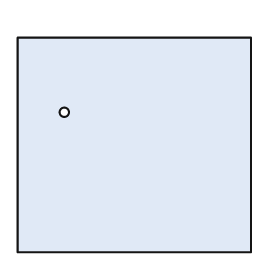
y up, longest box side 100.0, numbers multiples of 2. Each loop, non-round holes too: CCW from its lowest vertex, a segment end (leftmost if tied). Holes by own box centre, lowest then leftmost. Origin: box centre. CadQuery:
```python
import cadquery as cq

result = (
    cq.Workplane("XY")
    .moveTo(-50.0, -46.0)
    .lineTo(50.0, -46.0)
    .lineTo(50.0, 46.0)
    .lineTo(-50.0, 46.0)
    .close()
    .moveTo(-30.0, 14.0)
    .circle(2.0)
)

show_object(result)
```